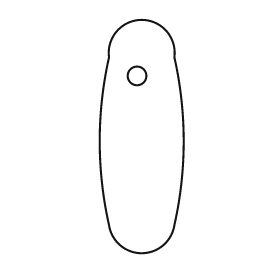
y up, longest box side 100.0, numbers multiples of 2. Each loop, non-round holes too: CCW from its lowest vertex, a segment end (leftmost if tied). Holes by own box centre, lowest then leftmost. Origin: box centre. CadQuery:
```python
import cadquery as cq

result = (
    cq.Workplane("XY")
    .moveTo(-14.0, -38.0)
    .threePointArc((0.0, -50.0), (14.0, -38.0))
    .threePointArc((18.0, -2.0), (14.0, 34.0))
    .threePointArc((0.0, 50.0), (-14.0, 34.0))
    .threePointArc((-18.0, -2.0), (-14.0, -38.0))
    .close()
    .moveTo(-2.0, 26.0)
    .circle(4.0)
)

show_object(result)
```